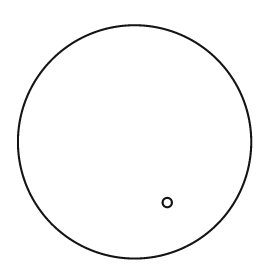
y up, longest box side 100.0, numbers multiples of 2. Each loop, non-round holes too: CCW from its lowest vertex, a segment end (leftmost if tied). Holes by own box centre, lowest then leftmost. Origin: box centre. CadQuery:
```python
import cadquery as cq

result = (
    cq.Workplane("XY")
    .moveTo(0.0, 0.0)
    .circle(50.0)
    .moveTo(14.0, -26.0)
    .circle(2.0)
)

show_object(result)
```